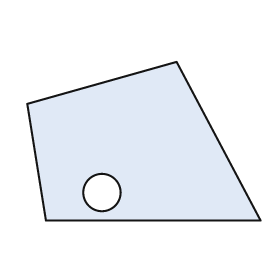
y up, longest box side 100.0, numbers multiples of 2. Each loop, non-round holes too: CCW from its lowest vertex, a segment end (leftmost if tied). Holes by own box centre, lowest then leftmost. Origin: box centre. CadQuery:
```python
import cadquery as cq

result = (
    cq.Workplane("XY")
    .moveTo(-42.0, -34.0)
    .lineTo(50.0, -34.0)
    .lineTo(14.0, 34.0)
    .lineTo(-50.0, 16.0)
    .close()
    .moveTo(-18.0, -22.0)
    .circle(8.0)
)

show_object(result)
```